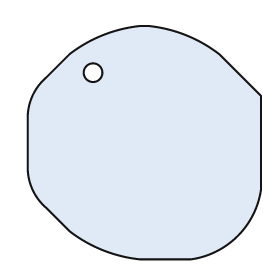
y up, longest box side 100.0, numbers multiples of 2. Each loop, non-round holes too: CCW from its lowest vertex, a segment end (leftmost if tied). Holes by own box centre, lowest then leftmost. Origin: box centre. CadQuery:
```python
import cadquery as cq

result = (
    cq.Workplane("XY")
    .moveTo(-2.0, -50.0)
    .lineTo(20.0, -50.0)
    .threePointArc((40.0, -40.0), (50.0, -20.0))
    .lineTo(50.0, 20.0)
    .lineTo(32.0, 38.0)
    .threePointArc((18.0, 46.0), (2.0, 50.0))
    .lineTo(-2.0, 50.0)
    .threePointArc((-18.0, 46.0), (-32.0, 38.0))
    .lineTo(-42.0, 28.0)
    .threePointArc((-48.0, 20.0), (-50.0, 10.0))
    .lineTo(-50.0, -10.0)
    .threePointArc((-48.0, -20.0), (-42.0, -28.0))
    .lineTo(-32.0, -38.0)
    .threePointArc((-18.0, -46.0), (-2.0, -50.0))
    .close()
    .moveTo(-22.0, 30.0)
    .circle(4.0)
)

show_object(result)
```